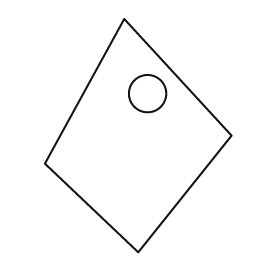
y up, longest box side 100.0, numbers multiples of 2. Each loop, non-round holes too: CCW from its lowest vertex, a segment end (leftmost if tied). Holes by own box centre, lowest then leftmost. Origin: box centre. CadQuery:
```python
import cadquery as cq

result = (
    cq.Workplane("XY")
    .moveTo(0.0, -50.0)
    .lineTo(40.0, 0.0)
    .lineTo(-6.0, 50.0)
    .lineTo(-40.0, -12.0)
    .close()
    .moveTo(4.0, 18.0)
    .circle(8.0)
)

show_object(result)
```